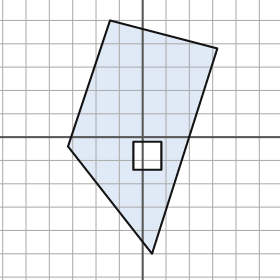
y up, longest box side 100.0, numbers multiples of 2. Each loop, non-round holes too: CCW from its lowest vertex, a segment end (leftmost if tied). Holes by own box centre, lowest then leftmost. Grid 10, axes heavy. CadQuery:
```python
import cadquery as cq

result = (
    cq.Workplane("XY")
    .moveTo(4.0, -50.0)
    .lineTo(32.0, 38.0)
    .lineTo(-14.0, 50.0)
    .lineTo(-32.0, -4.0)
    .close()
    .moveTo(-4.0, -14.0)
    .lineTo(8.0, -14.0)
    .lineTo(8.0, -2.0)
    .lineTo(-4.0, -2.0)
    .close()
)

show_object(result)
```